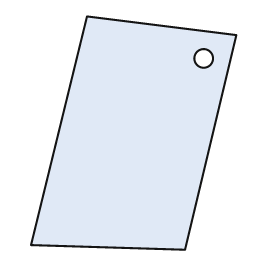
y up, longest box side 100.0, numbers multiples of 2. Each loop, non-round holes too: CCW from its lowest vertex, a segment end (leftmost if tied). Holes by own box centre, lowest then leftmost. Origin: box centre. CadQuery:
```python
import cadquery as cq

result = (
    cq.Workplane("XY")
    .moveTo(22.0, -50.0)
    .lineTo(44.0, 42.0)
    .lineTo(-20.0, 50.0)
    .lineTo(-44.0, -48.0)
    .close()
    .moveTo(30.0, 32.0)
    .circle(4.0)
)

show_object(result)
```